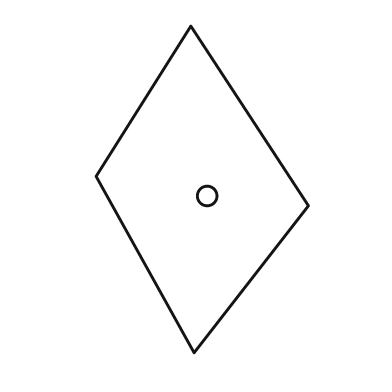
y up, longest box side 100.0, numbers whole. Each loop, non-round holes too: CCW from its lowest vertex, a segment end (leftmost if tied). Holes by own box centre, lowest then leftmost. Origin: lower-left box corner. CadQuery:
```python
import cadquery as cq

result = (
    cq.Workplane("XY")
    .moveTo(30.0, 0.0)
    .lineTo(65.0, 45.0)
    .lineTo(29.0, 100.0)
    .lineTo(0.0, 54.0)
    .close()
    .moveTo(34.0, 48.0)
    .circle(3.0)
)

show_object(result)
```